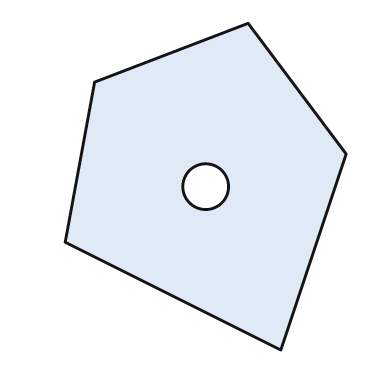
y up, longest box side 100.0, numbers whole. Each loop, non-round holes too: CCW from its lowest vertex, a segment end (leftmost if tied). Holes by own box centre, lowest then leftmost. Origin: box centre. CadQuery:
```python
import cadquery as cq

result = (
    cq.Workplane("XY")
    .moveTo(23.0, -50.0)
    .lineTo(43.0, 10.0)
    .lineTo(13.0, 50.0)
    .lineTo(-34.0, 32.0)
    .lineTo(-43.0, -17.0)
    .close()
    .moveTo(0.0, 0.0)
    .circle(7.0)
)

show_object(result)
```